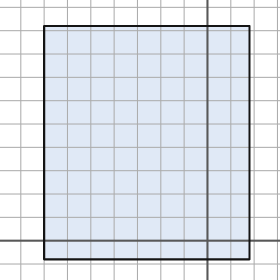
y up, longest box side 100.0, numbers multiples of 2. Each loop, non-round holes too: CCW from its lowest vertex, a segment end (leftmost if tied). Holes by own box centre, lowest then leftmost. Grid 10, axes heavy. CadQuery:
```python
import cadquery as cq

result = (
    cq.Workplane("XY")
    .moveTo(-70.0, -8.0)
    .lineTo(18.0, -8.0)
    .lineTo(18.0, 92.0)
    .lineTo(-70.0, 92.0)
    .close()
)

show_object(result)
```